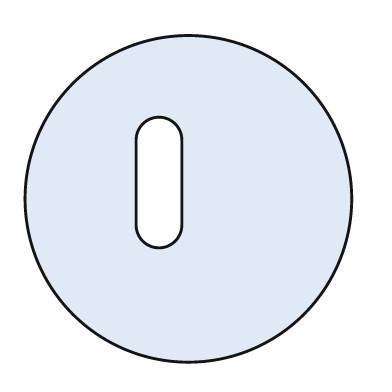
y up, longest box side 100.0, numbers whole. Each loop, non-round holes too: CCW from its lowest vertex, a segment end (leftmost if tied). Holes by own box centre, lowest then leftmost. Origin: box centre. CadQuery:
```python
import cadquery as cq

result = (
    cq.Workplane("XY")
    .moveTo(0.0, 0.0)
    .circle(50.0)
    .moveTo(-16.0, -8.0)
    .threePointArc((-9.0, -15.0), (-2.0, -8.0))
    .lineTo(-2.0, 18.0)
    .threePointArc((-9.0, 25.0), (-16.0, 18.0))
    .close()
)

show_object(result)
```